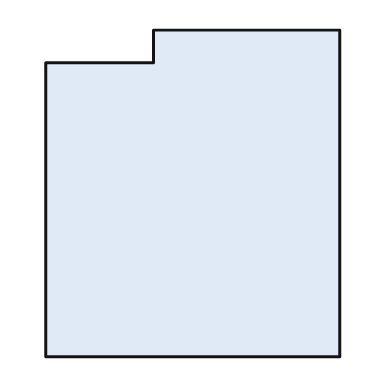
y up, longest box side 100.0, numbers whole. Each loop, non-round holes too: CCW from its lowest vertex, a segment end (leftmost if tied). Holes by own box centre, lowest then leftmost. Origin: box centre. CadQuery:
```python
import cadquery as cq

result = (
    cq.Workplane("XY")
    .moveTo(-45.0, -50.0)
    .lineTo(45.0, -50.0)
    .lineTo(45.0, 50.0)
    .lineTo(-12.0, 50.0)
    .lineTo(-12.0, 40.0)
    .lineTo(-45.0, 40.0)
    .close()
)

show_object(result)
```